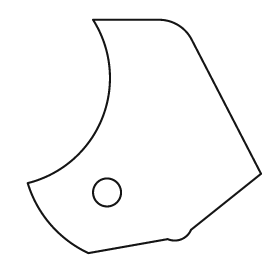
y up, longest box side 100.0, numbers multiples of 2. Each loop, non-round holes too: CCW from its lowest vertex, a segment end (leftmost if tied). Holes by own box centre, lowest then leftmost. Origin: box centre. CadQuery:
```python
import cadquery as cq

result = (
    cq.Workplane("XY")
    .moveTo(-24.0, -50.0)
    .lineTo(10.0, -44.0)
    .threePointArc((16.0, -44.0), (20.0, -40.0))
    .lineTo(50.0, -16.0)
    .lineTo(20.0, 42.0)
    .threePointArc((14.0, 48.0), (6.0, 50.0))
    .lineTo(-22.0, 50.0)
    .threePointArc((-18.0, 8.0), (-50.0, -20.0))
    .threePointArc((-40.0, -38.0), (-24.0, -50.0))
    .close()
    .moveTo(-16.0, -24.0)
    .circle(6.0)
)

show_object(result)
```